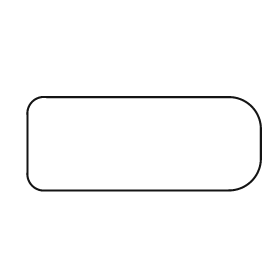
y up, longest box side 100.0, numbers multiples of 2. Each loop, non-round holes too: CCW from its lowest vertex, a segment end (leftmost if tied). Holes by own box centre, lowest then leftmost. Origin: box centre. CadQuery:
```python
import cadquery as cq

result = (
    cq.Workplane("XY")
    .moveTo(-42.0, -20.0)
    .lineTo(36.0, -20.0)
    .threePointArc((46.0, -16.0), (50.0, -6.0))
    .lineTo(50.0, 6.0)
    .threePointArc((46.0, 16.0), (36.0, 20.0))
    .lineTo(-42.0, 20.0)
    .threePointArc((-48.0, 18.0), (-50.0, 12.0))
    .lineTo(-50.0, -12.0)
    .threePointArc((-48.0, -18.0), (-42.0, -20.0))
    .close()
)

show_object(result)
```